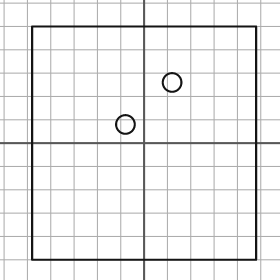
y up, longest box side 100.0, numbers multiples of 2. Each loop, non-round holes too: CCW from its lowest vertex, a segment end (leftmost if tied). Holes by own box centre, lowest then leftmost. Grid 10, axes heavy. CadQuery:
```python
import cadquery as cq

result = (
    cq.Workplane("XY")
    .moveTo(-48.0, -50.0)
    .lineTo(48.0, -50.0)
    .lineTo(48.0, 50.0)
    .lineTo(-48.0, 50.0)
    .close()
    .moveTo(-8.0, 8.0)
    .circle(4.0)
    .moveTo(12.0, 26.0)
    .circle(4.0)
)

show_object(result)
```